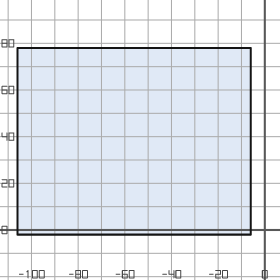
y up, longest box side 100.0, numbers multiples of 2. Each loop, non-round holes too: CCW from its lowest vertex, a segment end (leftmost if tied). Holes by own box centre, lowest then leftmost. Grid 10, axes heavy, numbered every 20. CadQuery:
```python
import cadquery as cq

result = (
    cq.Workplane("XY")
    .moveTo(-106.0, -2.0)
    .lineTo(-6.0, -2.0)
    .lineTo(-6.0, 78.0)
    .lineTo(-106.0, 78.0)
    .close()
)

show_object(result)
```